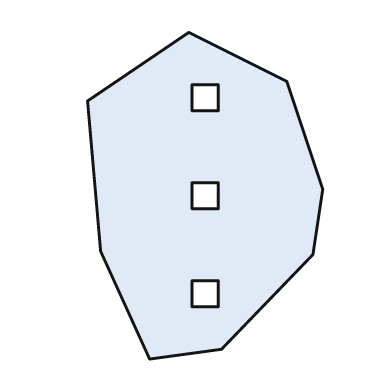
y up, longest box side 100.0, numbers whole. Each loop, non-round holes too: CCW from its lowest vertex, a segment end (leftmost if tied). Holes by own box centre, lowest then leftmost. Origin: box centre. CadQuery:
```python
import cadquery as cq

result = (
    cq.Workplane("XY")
    .moveTo(-17.0, -50.0)
    .lineTo(5.0, -47.0)
    .lineTo(33.0, -18.0)
    .lineTo(36.0, 2.0)
    .lineTo(25.0, 35.0)
    .lineTo(-5.0, 50.0)
    .lineTo(-36.0, 29.0)
    .lineTo(-32.0, -17.0)
    .close()
    .moveTo(-4.0, -34.0)
    .lineTo(4.0, -34.0)
    .lineTo(4.0, -26.0)
    .lineTo(-4.0, -26.0)
    .close()
    .moveTo(-4.0, -4.0)
    .lineTo(4.0, -4.0)
    .lineTo(4.0, 4.0)
    .lineTo(-4.0, 4.0)
    .close()
    .moveTo(-4.0, 26.0)
    .lineTo(4.0, 26.0)
    .lineTo(4.0, 34.0)
    .lineTo(-4.0, 34.0)
    .close()
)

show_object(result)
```